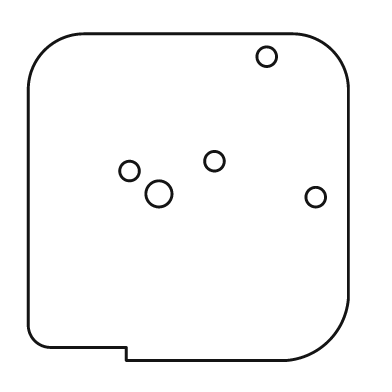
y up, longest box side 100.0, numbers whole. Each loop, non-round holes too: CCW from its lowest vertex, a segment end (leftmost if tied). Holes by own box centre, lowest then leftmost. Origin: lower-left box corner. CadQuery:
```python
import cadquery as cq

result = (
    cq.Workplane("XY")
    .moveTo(30.0, 0.0)
    .lineTo(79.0, 0.0)
    .threePointArc((92.0, 6.0), (98.0, 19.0))
    .lineTo(98.0, 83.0)
    .threePointArc((93.0, 95.0), (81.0, 100.0))
    .lineTo(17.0, 100.0)
    .threePointArc((5.0, 95.0), (0.0, 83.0))
    .lineTo(0.0, 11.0)
    .threePointArc((2.0, 6.0), (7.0, 4.0))
    .lineTo(30.0, 4.0)
    .close()
    .moveTo(88.0, 50.0)
    .circle(3.0)
    .moveTo(40.0, 51.0)
    .circle(4.0)
    .moveTo(31.0, 58.0)
    .circle(3.0)
    .moveTo(57.0, 61.0)
    .circle(3.0)
    .moveTo(73.0, 93.0)
    .circle(3.0)
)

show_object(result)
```